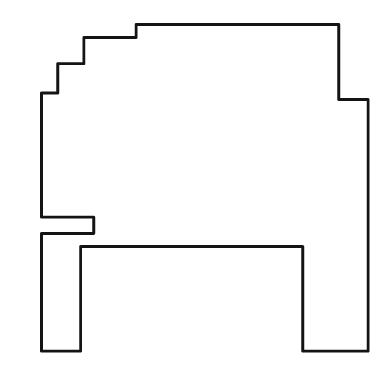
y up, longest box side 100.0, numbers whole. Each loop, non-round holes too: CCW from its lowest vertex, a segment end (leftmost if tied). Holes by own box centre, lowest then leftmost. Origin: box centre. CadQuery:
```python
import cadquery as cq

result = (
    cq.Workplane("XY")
    .moveTo(-50.0, -50.0)
    .lineTo(-38.0, -50.0)
    .lineTo(-38.0, -18.0)
    .lineTo(30.0, -18.0)
    .lineTo(30.0, -50.0)
    .lineTo(50.0, -50.0)
    .lineTo(50.0, 27.0)
    .lineTo(41.0, 27.0)
    .lineTo(41.0, 50.0)
    .lineTo(-21.0, 50.0)
    .lineTo(-21.0, 46.0)
    .lineTo(-37.0, 46.0)
    .lineTo(-37.0, 38.0)
    .lineTo(-45.0, 38.0)
    .lineTo(-45.0, 29.0)
    .lineTo(-50.0, 29.0)
    .lineTo(-50.0, -9.0)
    .lineTo(-34.0, -9.0)
    .lineTo(-34.0, -14.0)
    .lineTo(-50.0, -14.0)
    .close()
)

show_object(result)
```